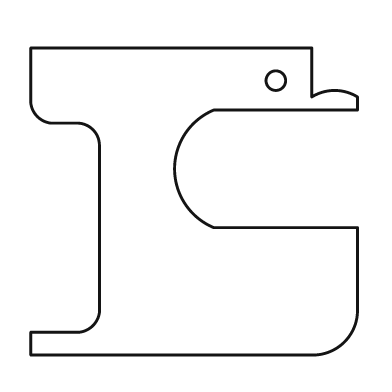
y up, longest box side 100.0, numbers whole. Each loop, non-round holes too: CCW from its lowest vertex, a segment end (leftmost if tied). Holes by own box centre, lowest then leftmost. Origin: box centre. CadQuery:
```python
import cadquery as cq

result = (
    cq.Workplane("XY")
    .moveTo(-50.0, -47.0)
    .lineTo(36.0, -47.0)
    .threePointArc((46.0, -43.0), (50.0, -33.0))
    .lineTo(50.0, -8.0)
    .lineTo(6.0, -8.0)
    .threePointArc((-6.0, 10.0), (6.0, 28.0))
    .lineTo(50.0, 28.0)
    .lineTo(50.0, 32.0)
    .threePointArc((43.0, 34.0), (36.0, 32.0))
    .lineTo(36.0, 47.0)
    .lineTo(-50.0, 47.0)
    .lineTo(-50.0, 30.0)
    .threePointArc((-48.0, 26.0), (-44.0, 24.0))
    .lineTo(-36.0, 24.0)
    .threePointArc((-31.0, 22.0), (-29.0, 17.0))
    .lineTo(-29.0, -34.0)
    .threePointArc((-31.0, -38.0), (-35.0, -40.0))
    .lineTo(-50.0, -40.0)
    .close()
    .moveTo(25.0, 37.0)
    .circle(3.0)
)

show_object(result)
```